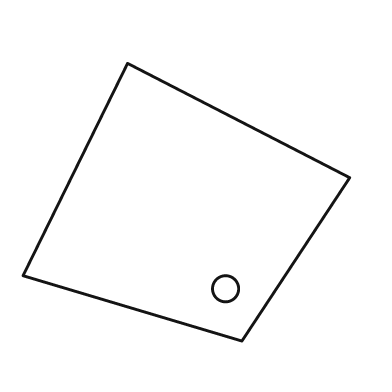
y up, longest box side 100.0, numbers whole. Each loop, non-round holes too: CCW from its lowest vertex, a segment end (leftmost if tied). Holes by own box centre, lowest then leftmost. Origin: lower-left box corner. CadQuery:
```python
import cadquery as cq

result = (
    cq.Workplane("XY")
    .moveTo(67.0, 0.0)
    .lineTo(100.0, 50.0)
    .lineTo(32.0, 85.0)
    .lineTo(0.0, 20.0)
    .close()
    .moveTo(62.0, 16.0)
    .circle(4.0)
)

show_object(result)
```